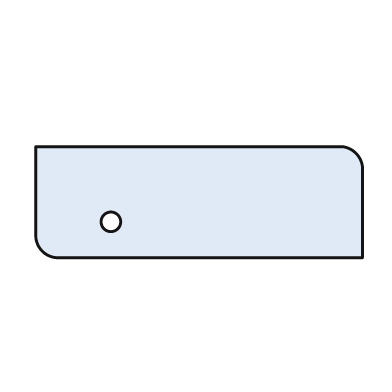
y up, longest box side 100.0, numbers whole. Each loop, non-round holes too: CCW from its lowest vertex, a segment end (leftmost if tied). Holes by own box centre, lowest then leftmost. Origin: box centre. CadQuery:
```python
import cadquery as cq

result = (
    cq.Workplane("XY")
    .moveTo(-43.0, -17.0)
    .lineTo(50.0, -17.0)
    .lineTo(50.0, 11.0)
    .threePointArc((48.0, 15.0), (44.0, 17.0))
    .lineTo(-50.0, 17.0)
    .lineTo(-50.0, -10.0)
    .threePointArc((-48.0, -15.0), (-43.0, -17.0))
    .close()
    .moveTo(-27.0, -6.0)
    .circle(3.0)
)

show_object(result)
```